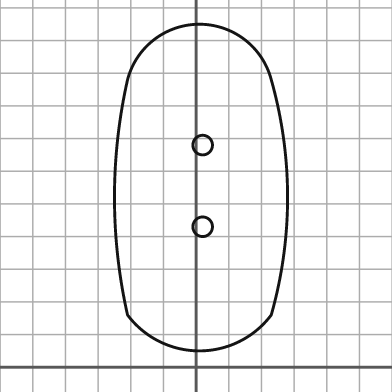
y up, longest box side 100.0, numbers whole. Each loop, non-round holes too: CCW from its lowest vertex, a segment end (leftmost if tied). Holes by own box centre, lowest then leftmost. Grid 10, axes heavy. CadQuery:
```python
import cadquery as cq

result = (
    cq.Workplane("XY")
    .moveTo(-21.0, 16.0)
    .threePointArc((1.0, 5.0), (23.0, 16.0))
    .threePointArc((28.0, 52.0), (23.0, 88.0))
    .threePointArc((1.0, 105.0), (-21.0, 88.0))
    .threePointArc((-25.0, 52.0), (-21.0, 16.0))
    .close()
    .moveTo(2.0, 43.0)
    .circle(3.0)
    .moveTo(2.0, 68.0)
    .circle(3.0)
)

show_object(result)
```